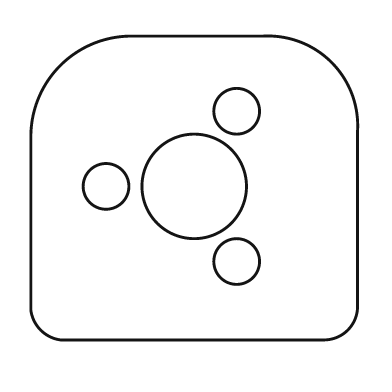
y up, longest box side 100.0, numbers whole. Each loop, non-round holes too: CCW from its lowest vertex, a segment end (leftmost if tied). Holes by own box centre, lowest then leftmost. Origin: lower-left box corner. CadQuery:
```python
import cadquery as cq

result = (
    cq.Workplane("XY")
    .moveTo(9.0, 0.0)
    .lineTo(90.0, 0.0)
    .threePointArc((97.0, 3.0), (100.0, 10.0))
    .lineTo(100.0, 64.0)
    .threePointArc((92.0, 85.0), (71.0, 93.0))
    .lineTo(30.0, 93.0)
    .threePointArc((9.0, 84.0), (0.0, 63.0))
    .lineTo(0.0, 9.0)
    .threePointArc((3.0, 3.0), (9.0, 0.0))
    .close()
    .moveTo(63.0, 24.0)
    .circle(7.0)
    .moveTo(23.0, 47.0)
    .circle(7.0)
    .moveTo(50.0, 47.0)
    .circle(16.0)
    .moveTo(63.0, 70.0)
    .circle(7.0)
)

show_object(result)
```